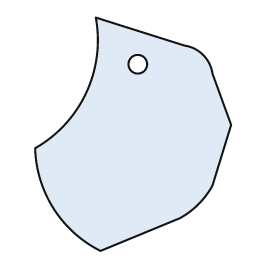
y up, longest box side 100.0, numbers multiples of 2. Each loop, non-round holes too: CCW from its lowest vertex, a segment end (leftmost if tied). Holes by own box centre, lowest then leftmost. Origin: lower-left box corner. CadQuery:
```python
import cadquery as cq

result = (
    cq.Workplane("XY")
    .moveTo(28.0, 0.0)
    .lineTo(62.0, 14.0)
    .threePointArc((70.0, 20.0), (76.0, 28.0))
    .lineTo(84.0, 54.0)
    .lineTo(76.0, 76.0)
    .threePointArc((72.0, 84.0), (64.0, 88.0))
    .lineTo(26.0, 100.0)
    .threePointArc((22.0, 68.0), (0.0, 44.0))
    .threePointArc((8.0, 18.0), (28.0, 0.0))
    .close()
    .moveTo(44.0, 80.0)
    .circle(4.0)
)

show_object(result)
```